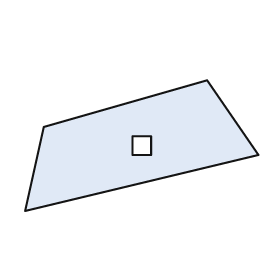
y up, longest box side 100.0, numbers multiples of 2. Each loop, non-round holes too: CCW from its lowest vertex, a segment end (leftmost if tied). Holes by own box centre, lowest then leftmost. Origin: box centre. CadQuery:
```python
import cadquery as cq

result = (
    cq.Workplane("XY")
    .moveTo(-50.0, -28.0)
    .lineTo(50.0, -4.0)
    .lineTo(28.0, 28.0)
    .lineTo(-42.0, 8.0)
    .close()
    .moveTo(-4.0, -4.0)
    .lineTo(4.0, -4.0)
    .lineTo(4.0, 4.0)
    .lineTo(-4.0, 4.0)
    .close()
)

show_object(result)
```